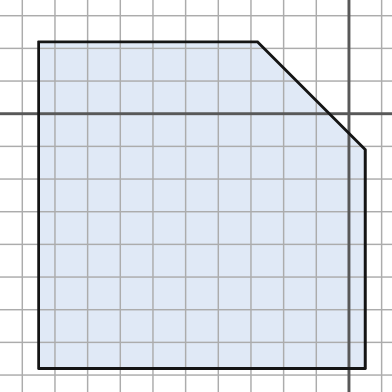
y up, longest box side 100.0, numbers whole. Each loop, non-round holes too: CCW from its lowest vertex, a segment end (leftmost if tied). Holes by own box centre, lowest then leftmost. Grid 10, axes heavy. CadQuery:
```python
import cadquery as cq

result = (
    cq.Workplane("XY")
    .moveTo(-95.0, -78.0)
    .lineTo(5.0, -78.0)
    .lineTo(5.0, -11.0)
    .lineTo(-28.0, 22.0)
    .lineTo(-95.0, 22.0)
    .close()
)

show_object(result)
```